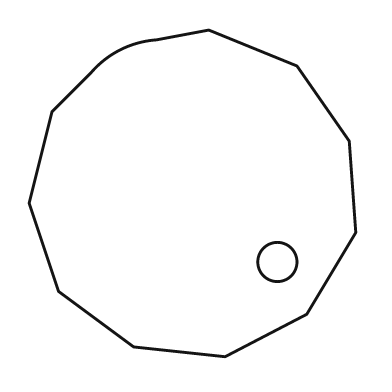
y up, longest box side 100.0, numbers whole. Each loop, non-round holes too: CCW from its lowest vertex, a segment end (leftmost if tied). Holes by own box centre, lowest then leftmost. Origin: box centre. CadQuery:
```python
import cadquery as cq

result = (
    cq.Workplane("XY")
    .moveTo(10.0, -50.0)
    .lineTo(35.0, -37.0)
    .lineTo(50.0, -12.0)
    .lineTo(48.0, 16.0)
    .lineTo(32.0, 39.0)
    .lineTo(5.0, 50.0)
    .lineTo(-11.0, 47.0)
    .threePointArc((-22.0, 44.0), (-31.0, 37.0))
    .lineTo(-43.0, 25.0)
    .lineTo(-50.0, -3.0)
    .lineTo(-41.0, -30.0)
    .lineTo(-18.0, -47.0)
    .close()
    .moveTo(26.0, -21.0)
    .circle(6.0)
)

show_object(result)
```